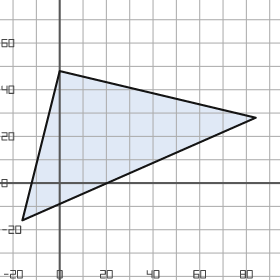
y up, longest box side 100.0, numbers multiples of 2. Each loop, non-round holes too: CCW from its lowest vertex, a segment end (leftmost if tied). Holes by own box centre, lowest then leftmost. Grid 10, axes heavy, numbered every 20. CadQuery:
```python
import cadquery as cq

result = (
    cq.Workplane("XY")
    .moveTo(-16.0, -16.0)
    .lineTo(84.0, 28.0)
    .lineTo(0.0, 48.0)
    .close()
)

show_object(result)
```